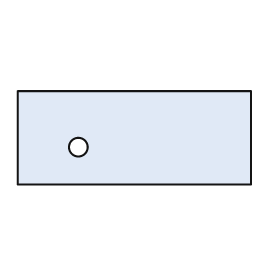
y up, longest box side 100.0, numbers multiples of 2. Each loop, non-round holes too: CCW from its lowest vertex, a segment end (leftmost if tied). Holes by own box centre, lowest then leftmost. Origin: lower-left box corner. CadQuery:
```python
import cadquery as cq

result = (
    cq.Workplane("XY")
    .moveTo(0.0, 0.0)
    .lineTo(100.0, 0.0)
    .lineTo(100.0, 40.0)
    .lineTo(0.0, 40.0)
    .close()
    .moveTo(26.0, 16.0)
    .circle(4.0)
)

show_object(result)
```